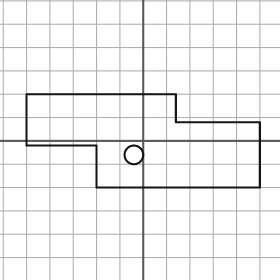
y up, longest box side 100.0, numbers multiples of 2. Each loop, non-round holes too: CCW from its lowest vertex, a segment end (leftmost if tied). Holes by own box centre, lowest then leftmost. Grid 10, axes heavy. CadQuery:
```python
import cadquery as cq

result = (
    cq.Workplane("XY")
    .moveTo(-20.0, -20.0)
    .lineTo(50.0, -20.0)
    .lineTo(50.0, 8.0)
    .lineTo(14.0, 8.0)
    .lineTo(14.0, 20.0)
    .lineTo(-50.0, 20.0)
    .lineTo(-50.0, -2.0)
    .lineTo(-20.0, -2.0)
    .close()
    .moveTo(-4.0, -6.0)
    .circle(4.0)
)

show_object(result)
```